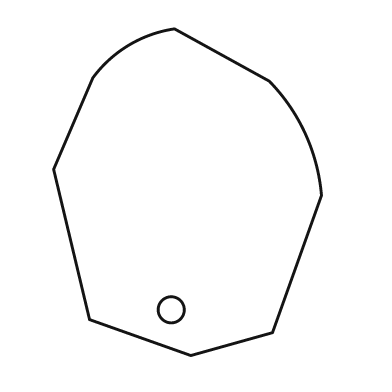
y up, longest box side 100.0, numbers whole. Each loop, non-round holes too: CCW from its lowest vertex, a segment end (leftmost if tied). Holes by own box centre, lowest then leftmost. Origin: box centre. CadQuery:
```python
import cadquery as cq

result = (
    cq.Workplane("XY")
    .moveTo(1.0, -50.0)
    .lineTo(26.0, -43.0)
    .lineTo(41.0, -1.0)
    .threePointArc((36.0, 18.0), (25.0, 34.0))
    .lineTo(-4.0, 50.0)
    .threePointArc((-18.0, 45.0), (-29.0, 35.0))
    .lineTo(-41.0, 7.0)
    .lineTo(-30.0, -39.0)
    .close()
    .moveTo(-5.0, -36.0)
    .circle(4.0)
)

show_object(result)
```